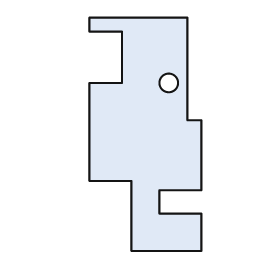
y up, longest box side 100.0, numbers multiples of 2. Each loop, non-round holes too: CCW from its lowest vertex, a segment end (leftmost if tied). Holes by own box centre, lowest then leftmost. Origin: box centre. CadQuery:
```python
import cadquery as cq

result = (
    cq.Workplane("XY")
    .moveTo(-6.0, -50.0)
    .lineTo(24.0, -50.0)
    .lineTo(24.0, -34.0)
    .lineTo(6.0, -34.0)
    .lineTo(6.0, -24.0)
    .lineTo(24.0, -24.0)
    .lineTo(24.0, 6.0)
    .lineTo(18.0, 6.0)
    .lineTo(18.0, 50.0)
    .lineTo(-24.0, 50.0)
    .lineTo(-24.0, 44.0)
    .lineTo(-10.0, 44.0)
    .lineTo(-10.0, 22.0)
    .lineTo(-24.0, 22.0)
    .lineTo(-24.0, -20.0)
    .lineTo(-6.0, -20.0)
    .close()
    .moveTo(10.0, 22.0)
    .circle(4.0)
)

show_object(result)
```